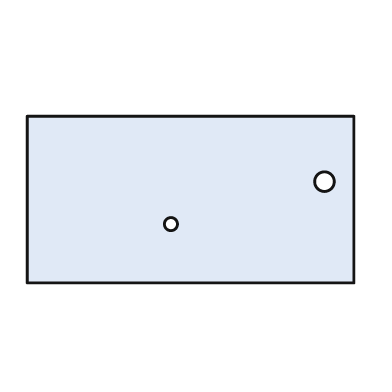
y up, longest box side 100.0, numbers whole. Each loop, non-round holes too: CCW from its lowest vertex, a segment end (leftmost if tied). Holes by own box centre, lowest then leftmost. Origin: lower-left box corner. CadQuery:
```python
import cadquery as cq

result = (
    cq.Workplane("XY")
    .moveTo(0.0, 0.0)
    .lineTo(100.0, 0.0)
    .lineTo(100.0, 51.0)
    .lineTo(0.0, 51.0)
    .close()
    .moveTo(44.0, 18.0)
    .circle(2.0)
    .moveTo(91.0, 31.0)
    .circle(3.0)
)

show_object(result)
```